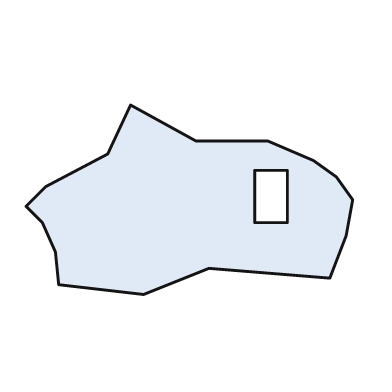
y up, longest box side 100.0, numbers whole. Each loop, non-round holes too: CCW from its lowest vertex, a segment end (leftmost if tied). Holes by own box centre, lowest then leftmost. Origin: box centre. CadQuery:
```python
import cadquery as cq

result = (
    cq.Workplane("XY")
    .moveTo(-14.0, -29.0)
    .lineTo(6.0, -21.0)
    .lineTo(43.0, -24.0)
    .lineTo(48.0, -11.0)
    .lineTo(50.0, 0.0)
    .lineTo(45.0, 7.0)
    .lineTo(38.0, 12.0)
    .lineTo(24.0, 18.0)
    .lineTo(2.0, 18.0)
    .lineTo(-18.0, 29.0)
    .lineTo(-25.0, 14.0)
    .lineTo(-44.0, 4.0)
    .lineTo(-50.0, -2.0)
    .lineTo(-45.0, -7.0)
    .lineTo(-41.0, -16.0)
    .lineTo(-40.0, -26.0)
    .close()
    .moveTo(20.0, -7.0)
    .lineTo(30.0, -7.0)
    .lineTo(30.0, 9.0)
    .lineTo(20.0, 9.0)
    .close()
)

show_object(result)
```